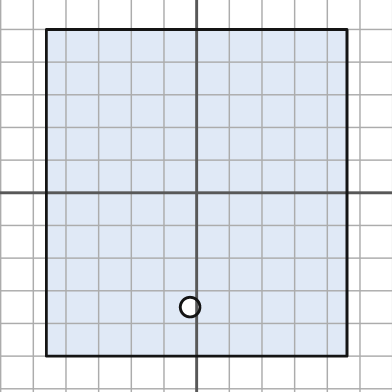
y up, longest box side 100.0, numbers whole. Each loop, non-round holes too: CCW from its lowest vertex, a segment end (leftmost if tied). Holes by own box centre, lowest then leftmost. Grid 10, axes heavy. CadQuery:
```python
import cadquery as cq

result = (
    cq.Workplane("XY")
    .moveTo(-46.0, -50.0)
    .lineTo(46.0, -50.0)
    .lineTo(46.0, 50.0)
    .lineTo(-46.0, 50.0)
    .close()
    .moveTo(-2.0, -35.0)
    .circle(3.0)
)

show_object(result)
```